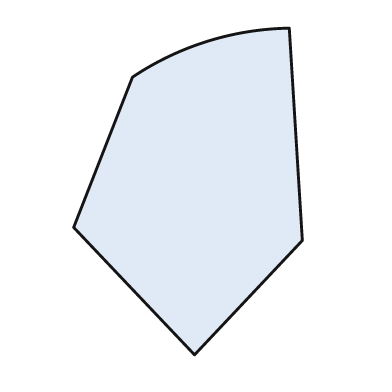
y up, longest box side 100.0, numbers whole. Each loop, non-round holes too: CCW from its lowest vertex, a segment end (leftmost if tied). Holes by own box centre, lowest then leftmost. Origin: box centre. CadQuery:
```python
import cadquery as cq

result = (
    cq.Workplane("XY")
    .moveTo(2.0, -50.0)
    .lineTo(35.0, -15.0)
    .lineTo(31.0, 50.0)
    .threePointArc((6.0, 46.0), (-17.0, 35.0))
    .lineTo(-35.0, -11.0)
    .close()
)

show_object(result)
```